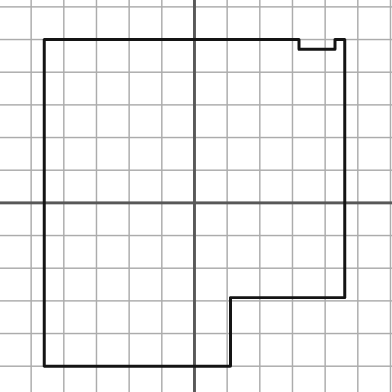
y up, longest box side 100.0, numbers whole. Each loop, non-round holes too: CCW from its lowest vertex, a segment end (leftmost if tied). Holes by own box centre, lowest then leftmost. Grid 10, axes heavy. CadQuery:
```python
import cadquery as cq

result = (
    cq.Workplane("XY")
    .moveTo(-46.0, -50.0)
    .lineTo(11.0, -50.0)
    .lineTo(11.0, -29.0)
    .lineTo(46.0, -29.0)
    .lineTo(46.0, 50.0)
    .lineTo(43.0, 50.0)
    .lineTo(43.0, 47.0)
    .lineTo(32.0, 47.0)
    .lineTo(32.0, 50.0)
    .lineTo(-46.0, 50.0)
    .close()
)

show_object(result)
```